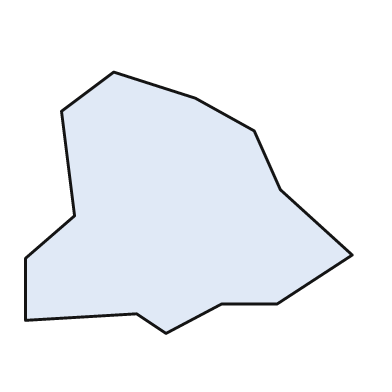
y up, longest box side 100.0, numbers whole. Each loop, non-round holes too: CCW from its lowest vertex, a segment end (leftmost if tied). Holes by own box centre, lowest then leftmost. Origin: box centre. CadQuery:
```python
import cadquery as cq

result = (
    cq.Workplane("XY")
    .moveTo(-7.0, -40.0)
    .lineTo(10.0, -31.0)
    .lineTo(27.0, -31.0)
    .lineTo(50.0, -16.0)
    .lineTo(28.0, 4.0)
    .lineTo(20.0, 22.0)
    .lineTo(2.0, 32.0)
    .lineTo(-23.0, 40.0)
    .lineTo(-39.0, 28.0)
    .lineTo(-35.0, -4.0)
    .lineTo(-50.0, -17.0)
    .lineTo(-50.0, -36.0)
    .lineTo(-16.0, -34.0)
    .close()
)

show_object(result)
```